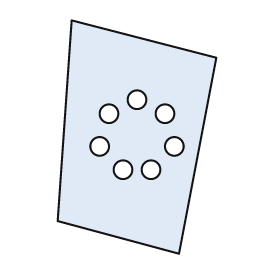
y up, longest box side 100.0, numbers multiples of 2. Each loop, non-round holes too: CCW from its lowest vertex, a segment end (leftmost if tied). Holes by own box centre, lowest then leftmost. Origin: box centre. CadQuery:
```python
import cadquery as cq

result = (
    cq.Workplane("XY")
    .moveTo(18.0, -50.0)
    .lineTo(34.0, 34.0)
    .lineTo(-28.0, 50.0)
    .lineTo(-34.0, -36.0)
    .close()
    .moveTo(-6.0, -14.0)
    .circle(4.0)
    .moveTo(6.0, -14.0)
    .circle(4.0)
    .moveTo(-16.0, -4.0)
    .circle(4.0)
    .moveTo(16.0, -4.0)
    .circle(4.0)
    .moveTo(-12.0, 10.0)
    .circle(4.0)
    .moveTo(12.0, 10.0)
    .circle(4.0)
    .moveTo(0.0, 16.0)
    .circle(4.0)
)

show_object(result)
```